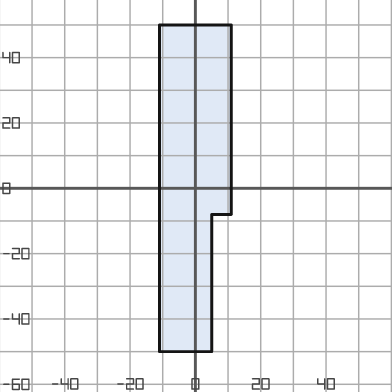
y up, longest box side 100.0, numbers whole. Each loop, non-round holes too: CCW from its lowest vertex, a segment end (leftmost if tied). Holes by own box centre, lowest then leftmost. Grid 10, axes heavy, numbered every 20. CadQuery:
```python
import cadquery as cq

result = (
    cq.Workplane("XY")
    .moveTo(-11.0, -50.0)
    .lineTo(5.0, -50.0)
    .lineTo(5.0, -8.0)
    .lineTo(11.0, -8.0)
    .lineTo(11.0, 50.0)
    .lineTo(-11.0, 50.0)
    .close()
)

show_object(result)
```